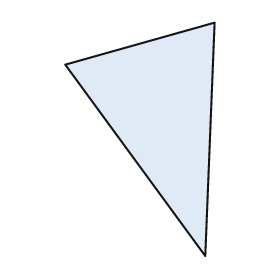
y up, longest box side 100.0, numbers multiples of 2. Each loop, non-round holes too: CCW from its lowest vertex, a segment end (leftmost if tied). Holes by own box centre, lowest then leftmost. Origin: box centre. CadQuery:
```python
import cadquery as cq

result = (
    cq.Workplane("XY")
    .moveTo(28.0, -50.0)
    .lineTo(32.0, 50.0)
    .lineTo(-32.0, 32.0)
    .close()
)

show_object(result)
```